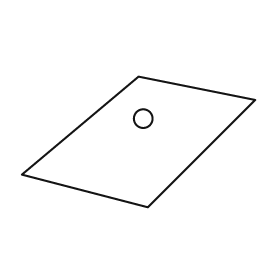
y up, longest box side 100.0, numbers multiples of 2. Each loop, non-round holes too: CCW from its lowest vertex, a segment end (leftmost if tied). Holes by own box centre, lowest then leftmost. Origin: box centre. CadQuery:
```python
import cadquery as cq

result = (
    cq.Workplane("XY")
    .moveTo(4.0, -28.0)
    .lineTo(50.0, 18.0)
    .lineTo(0.0, 28.0)
    .lineTo(-50.0, -14.0)
    .close()
    .moveTo(2.0, 10.0)
    .circle(4.0)
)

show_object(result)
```